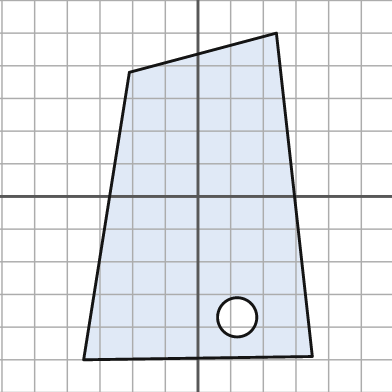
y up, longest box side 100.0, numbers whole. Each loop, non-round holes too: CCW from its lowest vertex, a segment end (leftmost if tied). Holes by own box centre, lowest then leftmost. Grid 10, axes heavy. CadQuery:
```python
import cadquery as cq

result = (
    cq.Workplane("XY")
    .moveTo(-35.0, -50.0)
    .lineTo(35.0, -49.0)
    .lineTo(24.0, 50.0)
    .lineTo(-21.0, 38.0)
    .close()
    .moveTo(12.0, -37.0)
    .circle(6.0)
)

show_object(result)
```